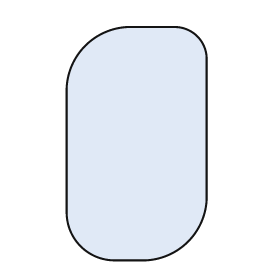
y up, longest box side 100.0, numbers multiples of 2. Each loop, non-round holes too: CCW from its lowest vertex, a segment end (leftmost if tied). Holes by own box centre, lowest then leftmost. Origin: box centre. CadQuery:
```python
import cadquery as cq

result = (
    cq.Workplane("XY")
    .moveTo(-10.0, -50.0)
    .lineTo(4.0, -50.0)
    .threePointArc((22.0, -42.0), (30.0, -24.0))
    .lineTo(30.0, 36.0)
    .threePointArc((26.0, 46.0), (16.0, 50.0))
    .lineTo(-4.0, 50.0)
    .threePointArc((-22.0, 42.0), (-30.0, 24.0))
    .lineTo(-30.0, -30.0)
    .threePointArc((-24.0, -44.0), (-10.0, -50.0))
    .close()
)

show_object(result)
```